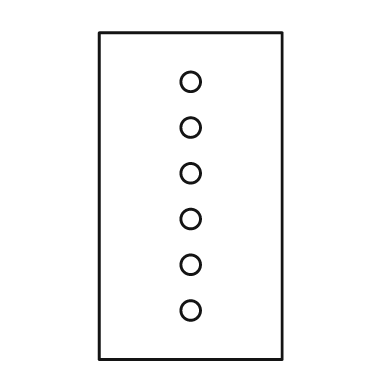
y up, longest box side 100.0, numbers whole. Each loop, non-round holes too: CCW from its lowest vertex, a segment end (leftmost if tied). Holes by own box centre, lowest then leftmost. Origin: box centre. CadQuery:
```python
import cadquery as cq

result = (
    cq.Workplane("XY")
    .moveTo(-28.0, -50.0)
    .lineTo(28.0, -50.0)
    .lineTo(28.0, 50.0)
    .lineTo(-28.0, 50.0)
    .close()
    .moveTo(0.0, -35.0)
    .circle(3.0)
    .moveTo(0.0, -21.0)
    .circle(3.0)
    .moveTo(0.0, -7.0)
    .circle(3.0)
    .moveTo(0.0, 7.0)
    .circle(3.0)
    .moveTo(0.0, 21.0)
    .circle(3.0)
    .moveTo(0.0, 35.0)
    .circle(3.0)
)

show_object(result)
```